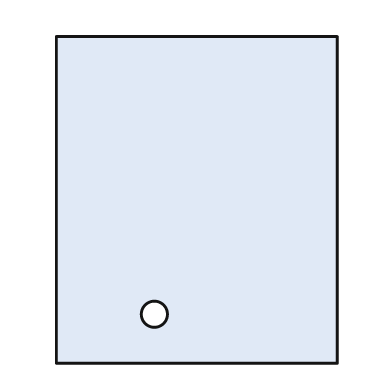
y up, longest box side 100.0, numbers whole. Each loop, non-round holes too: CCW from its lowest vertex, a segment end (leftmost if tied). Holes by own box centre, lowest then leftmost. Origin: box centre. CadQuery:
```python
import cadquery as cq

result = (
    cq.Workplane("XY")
    .moveTo(-43.0, -50.0)
    .lineTo(43.0, -50.0)
    .lineTo(43.0, 50.0)
    .lineTo(-43.0, 50.0)
    .close()
    .moveTo(-13.0, -35.0)
    .circle(4.0)
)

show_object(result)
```